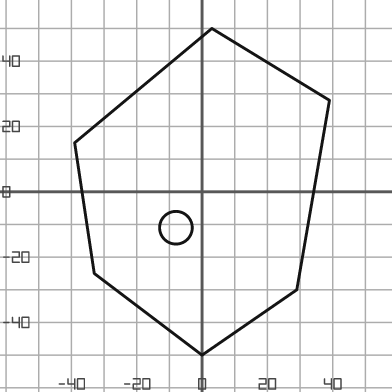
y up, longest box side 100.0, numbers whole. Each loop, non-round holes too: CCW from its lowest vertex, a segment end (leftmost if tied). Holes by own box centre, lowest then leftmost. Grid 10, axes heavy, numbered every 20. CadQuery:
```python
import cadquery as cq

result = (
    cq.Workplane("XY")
    .moveTo(0.0, -50.0)
    .lineTo(29.0, -30.0)
    .lineTo(39.0, 28.0)
    .lineTo(3.0, 50.0)
    .lineTo(-39.0, 15.0)
    .lineTo(-33.0, -25.0)
    .close()
    .moveTo(-8.0, -11.0)
    .circle(5.0)
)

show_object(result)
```